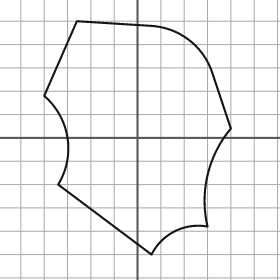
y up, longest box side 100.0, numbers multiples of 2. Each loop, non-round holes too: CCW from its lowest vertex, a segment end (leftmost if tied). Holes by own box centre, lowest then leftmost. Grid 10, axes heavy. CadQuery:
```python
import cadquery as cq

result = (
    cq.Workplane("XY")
    .moveTo(6.0, -50.0)
    .threePointArc((16.0, -40.0), (30.0, -38.0))
    .threePointArc((30.0, -16.0), (40.0, 4.0))
    .lineTo(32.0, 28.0)
    .threePointArc((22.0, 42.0), (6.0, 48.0))
    .lineTo(-26.0, 50.0)
    .lineTo(-40.0, 18.0)
    .threePointArc((-30.0, 0.0), (-34.0, -20.0))
    .close()
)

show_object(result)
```